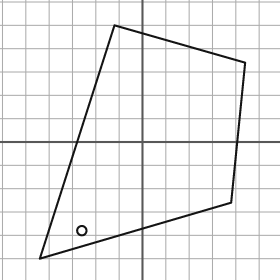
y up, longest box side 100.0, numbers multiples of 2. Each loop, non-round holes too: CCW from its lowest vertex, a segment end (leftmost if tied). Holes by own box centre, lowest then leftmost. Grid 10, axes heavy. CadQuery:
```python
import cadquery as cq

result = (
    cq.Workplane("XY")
    .moveTo(-44.0, -50.0)
    .lineTo(38.0, -26.0)
    .lineTo(44.0, 34.0)
    .lineTo(-12.0, 50.0)
    .close()
    .moveTo(-26.0, -38.0)
    .circle(2.0)
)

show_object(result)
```